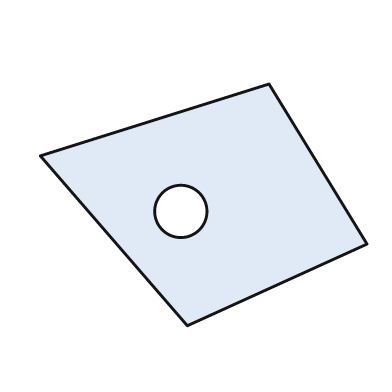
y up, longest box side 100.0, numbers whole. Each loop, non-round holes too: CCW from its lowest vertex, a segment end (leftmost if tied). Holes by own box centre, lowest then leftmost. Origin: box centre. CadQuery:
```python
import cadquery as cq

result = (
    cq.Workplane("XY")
    .moveTo(-5.0, -37.0)
    .lineTo(50.0, -12.0)
    .lineTo(20.0, 37.0)
    .lineTo(-50.0, 15.0)
    .close()
    .moveTo(-7.0, -2.0)
    .circle(8.0)
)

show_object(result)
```